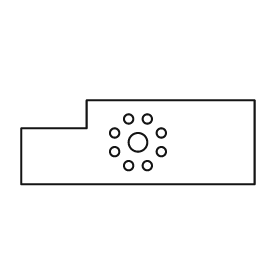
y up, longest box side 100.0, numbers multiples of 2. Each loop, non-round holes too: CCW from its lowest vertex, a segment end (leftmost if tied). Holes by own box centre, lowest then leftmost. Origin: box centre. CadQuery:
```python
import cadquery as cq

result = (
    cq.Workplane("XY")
    .moveTo(-50.0, -18.0)
    .lineTo(50.0, -18.0)
    .lineTo(50.0, 18.0)
    .lineTo(-22.0, 18.0)
    .lineTo(-22.0, 6.0)
    .lineTo(-50.0, 6.0)
    .close()
    .moveTo(-4.0, -10.0)
    .circle(2.0)
    .moveTo(4.0, -10.0)
    .circle(2.0)
    .moveTo(-10.0, -4.0)
    .circle(2.0)
    .moveTo(10.0, -4.0)
    .circle(2.0)
    .moveTo(0.0, 0.0)
    .circle(4.0)
    .moveTo(-10.0, 4.0)
    .circle(2.0)
    .moveTo(10.0, 4.0)
    .circle(2.0)
    .moveTo(-4.0, 10.0)
    .circle(2.0)
    .moveTo(4.0, 10.0)
    .circle(2.0)
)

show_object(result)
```